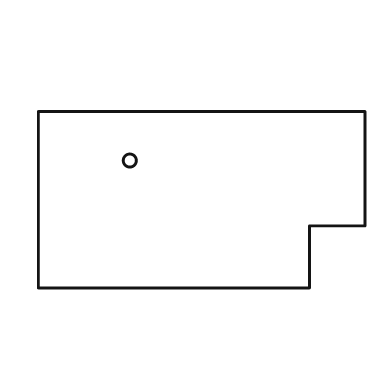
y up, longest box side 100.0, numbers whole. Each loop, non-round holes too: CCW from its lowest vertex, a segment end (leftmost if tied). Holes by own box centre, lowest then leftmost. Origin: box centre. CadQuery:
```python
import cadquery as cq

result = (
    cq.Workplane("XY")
    .moveTo(-50.0, -27.0)
    .lineTo(33.0, -27.0)
    .lineTo(33.0, -8.0)
    .lineTo(50.0, -8.0)
    .lineTo(50.0, 27.0)
    .lineTo(-50.0, 27.0)
    .close()
    .moveTo(-22.0, 12.0)
    .circle(2.0)
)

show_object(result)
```